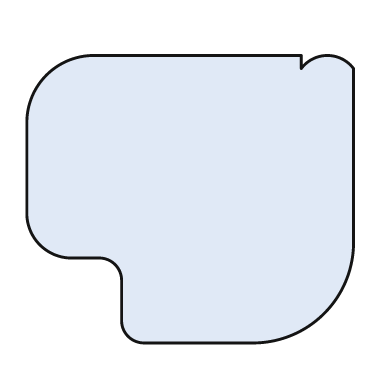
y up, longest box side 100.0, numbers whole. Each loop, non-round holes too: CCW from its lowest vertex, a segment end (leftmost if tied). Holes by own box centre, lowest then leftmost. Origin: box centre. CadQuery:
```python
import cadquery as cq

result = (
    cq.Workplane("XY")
    .moveTo(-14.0, -44.0)
    .lineTo(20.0, -44.0)
    .threePointArc((41.0, -35.0), (50.0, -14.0))
    .lineTo(50.0, 40.0)
    .threePointArc((42.0, 44.0), (34.0, 40.0))
    .lineTo(34.0, 44.0)
    .lineTo(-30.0, 44.0)
    .threePointArc((-44.0, 38.0), (-50.0, 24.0))
    .lineTo(-50.0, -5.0)
    .threePointArc((-46.0, -14.0), (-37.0, -18.0))
    .lineTo(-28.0, -18.0)
    .threePointArc((-23.0, -20.0), (-21.0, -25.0))
    .lineTo(-21.0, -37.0)
    .threePointArc((-19.0, -42.0), (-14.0, -44.0))
    .close()
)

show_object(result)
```